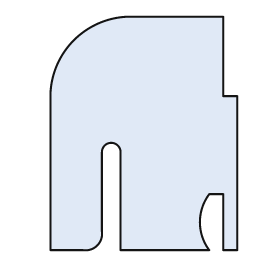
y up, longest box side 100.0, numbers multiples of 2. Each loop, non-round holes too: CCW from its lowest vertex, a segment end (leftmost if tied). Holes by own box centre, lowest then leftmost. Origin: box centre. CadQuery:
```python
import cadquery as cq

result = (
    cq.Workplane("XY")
    .moveTo(-40.0, -50.0)
    .lineTo(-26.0, -50.0)
    .threePointArc((-20.0, -48.0), (-18.0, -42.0))
    .lineTo(-18.0, -8.0)
    .threePointArc((-14.0, -4.0), (-10.0, -8.0))
    .lineTo(-10.0, -50.0)
    .lineTo(28.0, -50.0)
    .threePointArc((24.0, -38.0), (28.0, -26.0))
    .lineTo(34.0, -26.0)
    .lineTo(34.0, -50.0)
    .lineTo(40.0, -50.0)
    .lineTo(40.0, 16.0)
    .lineTo(34.0, 16.0)
    .lineTo(34.0, 50.0)
    .lineTo(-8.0, 50.0)
    .threePointArc((-30.0, 40.0), (-40.0, 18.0))
    .close()
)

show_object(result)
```